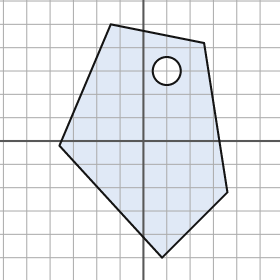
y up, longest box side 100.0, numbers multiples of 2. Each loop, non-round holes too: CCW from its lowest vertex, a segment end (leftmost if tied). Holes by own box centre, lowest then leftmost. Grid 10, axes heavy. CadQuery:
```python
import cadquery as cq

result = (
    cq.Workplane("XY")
    .moveTo(8.0, -50.0)
    .lineTo(36.0, -22.0)
    .lineTo(26.0, 42.0)
    .lineTo(-14.0, 50.0)
    .lineTo(-36.0, -2.0)
    .close()
    .moveTo(10.0, 30.0)
    .circle(6.0)
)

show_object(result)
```